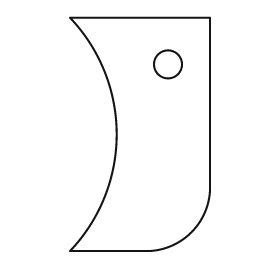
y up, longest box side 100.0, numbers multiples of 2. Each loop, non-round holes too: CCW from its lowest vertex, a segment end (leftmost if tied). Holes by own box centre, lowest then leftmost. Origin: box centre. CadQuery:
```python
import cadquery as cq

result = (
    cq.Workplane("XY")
    .moveTo(-30.0, -50.0)
    .lineTo(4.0, -50.0)
    .threePointArc((22.0, -42.0), (30.0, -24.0))
    .lineTo(30.0, 50.0)
    .lineTo(-30.0, 50.0)
    .threePointArc((-10.0, 0.0), (-30.0, -50.0))
    .close()
    .moveTo(12.0, 30.0)
    .circle(6.0)
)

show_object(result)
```